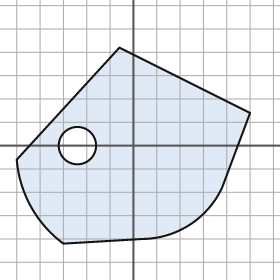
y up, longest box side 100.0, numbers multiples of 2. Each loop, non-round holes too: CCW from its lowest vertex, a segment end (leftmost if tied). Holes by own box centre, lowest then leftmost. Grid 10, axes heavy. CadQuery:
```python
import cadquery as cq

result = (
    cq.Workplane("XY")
    .moveTo(-30.0, -42.0)
    .lineTo(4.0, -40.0)
    .threePointArc((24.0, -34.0), (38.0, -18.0))
    .lineTo(50.0, 14.0)
    .lineTo(-6.0, 42.0)
    .lineTo(-50.0, -6.0)
    .threePointArc((-44.0, -26.0), (-30.0, -42.0))
    .close()
    .moveTo(-24.0, 0.0)
    .circle(8.0)
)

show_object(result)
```